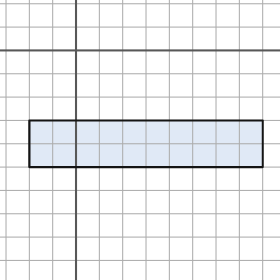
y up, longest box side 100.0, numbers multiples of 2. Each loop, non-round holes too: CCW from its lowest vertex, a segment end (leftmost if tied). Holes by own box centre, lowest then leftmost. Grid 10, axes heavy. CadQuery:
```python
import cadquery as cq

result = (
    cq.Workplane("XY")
    .moveTo(-20.0, -50.0)
    .lineTo(80.0, -50.0)
    .lineTo(80.0, -30.0)
    .lineTo(-20.0, -30.0)
    .close()
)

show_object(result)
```